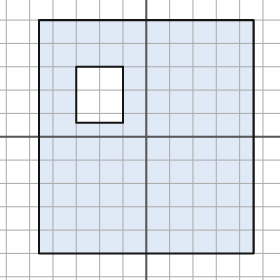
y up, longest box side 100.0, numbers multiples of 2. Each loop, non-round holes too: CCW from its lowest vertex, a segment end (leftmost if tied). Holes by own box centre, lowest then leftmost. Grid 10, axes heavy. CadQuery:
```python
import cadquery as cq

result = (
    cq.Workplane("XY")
    .moveTo(-46.0, -50.0)
    .lineTo(46.0, -50.0)
    .lineTo(46.0, 50.0)
    .lineTo(-46.0, 50.0)
    .close()
    .moveTo(-30.0, 6.0)
    .lineTo(-10.0, 6.0)
    .lineTo(-10.0, 30.0)
    .lineTo(-30.0, 30.0)
    .close()
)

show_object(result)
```